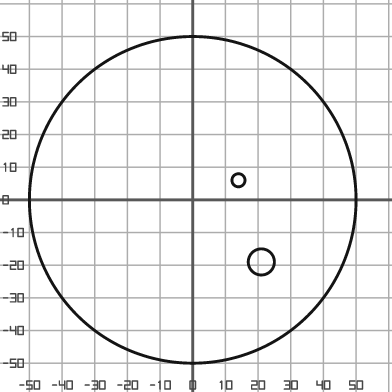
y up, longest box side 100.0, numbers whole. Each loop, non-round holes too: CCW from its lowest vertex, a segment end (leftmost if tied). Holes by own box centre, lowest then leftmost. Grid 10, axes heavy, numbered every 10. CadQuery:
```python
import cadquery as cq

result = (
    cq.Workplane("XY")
    .moveTo(0.0, 0.0)
    .circle(50.0)
    .moveTo(21.0, -19.0)
    .circle(4.0)
    .moveTo(14.0, 6.0)
    .circle(2.0)
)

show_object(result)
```